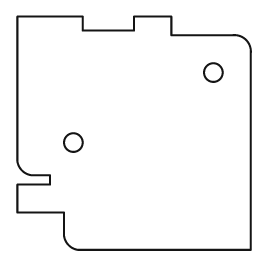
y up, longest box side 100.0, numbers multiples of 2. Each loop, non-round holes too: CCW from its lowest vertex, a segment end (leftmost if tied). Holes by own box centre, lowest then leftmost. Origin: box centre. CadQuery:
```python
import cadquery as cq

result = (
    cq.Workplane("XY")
    .moveTo(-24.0, -50.0)
    .lineTo(50.0, -50.0)
    .lineTo(50.0, 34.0)
    .threePointArc((48.0, 40.0), (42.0, 42.0))
    .lineTo(16.0, 42.0)
    .lineTo(16.0, 50.0)
    .lineTo(0.0, 50.0)
    .lineTo(0.0, 44.0)
    .lineTo(-22.0, 44.0)
    .lineTo(-22.0, 50.0)
    .lineTo(-50.0, 50.0)
    .lineTo(-50.0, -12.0)
    .threePointArc((-48.0, -16.0), (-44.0, -18.0))
    .lineTo(-36.0, -18.0)
    .lineTo(-36.0, -22.0)
    .lineTo(-50.0, -22.0)
    .lineTo(-50.0, -34.0)
    .lineTo(-30.0, -34.0)
    .lineTo(-30.0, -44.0)
    .threePointArc((-28.0, -48.0), (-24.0, -50.0))
    .close()
    .moveTo(-26.0, -4.0)
    .circle(4.0)
    .moveTo(34.0, 26.0)
    .circle(4.0)
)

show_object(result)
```